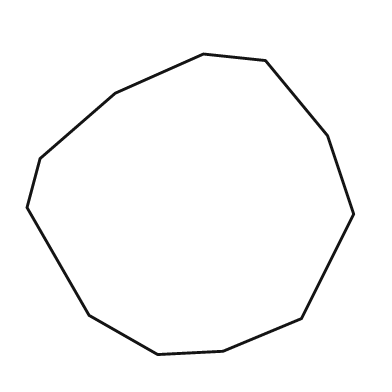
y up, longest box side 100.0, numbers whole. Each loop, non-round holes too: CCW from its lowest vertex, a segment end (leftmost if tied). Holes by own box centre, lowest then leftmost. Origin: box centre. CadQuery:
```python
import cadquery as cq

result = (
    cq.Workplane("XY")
    .moveTo(-10.0, -46.0)
    .lineTo(10.0, -45.0)
    .lineTo(34.0, -35.0)
    .lineTo(50.0, -3.0)
    .lineTo(42.0, 21.0)
    .lineTo(23.0, 44.0)
    .lineTo(4.0, 46.0)
    .lineTo(-23.0, 34.0)
    .lineTo(-46.0, 14.0)
    .lineTo(-50.0, -1.0)
    .lineTo(-31.0, -34.0)
    .close()
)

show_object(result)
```